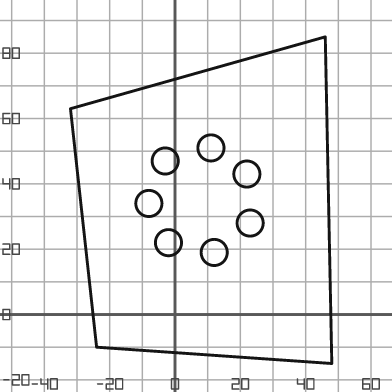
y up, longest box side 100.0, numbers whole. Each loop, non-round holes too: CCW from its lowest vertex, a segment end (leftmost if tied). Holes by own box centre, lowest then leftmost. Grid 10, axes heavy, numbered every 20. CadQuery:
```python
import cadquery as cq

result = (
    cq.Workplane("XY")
    .moveTo(48.0, -15.0)
    .lineTo(46.0, 85.0)
    .lineTo(-32.0, 63.0)
    .lineTo(-24.0, -10.0)
    .close()
    .moveTo(12.0, 19.0)
    .circle(4.0)
    .moveTo(-2.0, 22.0)
    .circle(4.0)
    .moveTo(23.0, 28.0)
    .circle(4.0)
    .moveTo(-8.0, 34.0)
    .circle(4.0)
    .moveTo(22.0, 43.0)
    .circle(4.0)
    .moveTo(-3.0, 47.0)
    .circle(4.0)
    .moveTo(11.0, 51.0)
    .circle(4.0)
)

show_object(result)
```